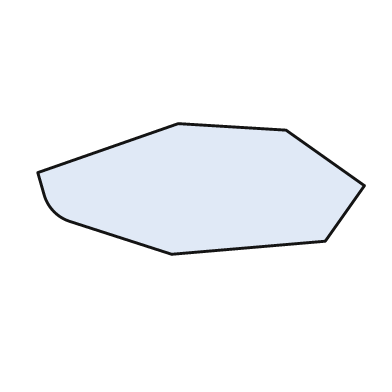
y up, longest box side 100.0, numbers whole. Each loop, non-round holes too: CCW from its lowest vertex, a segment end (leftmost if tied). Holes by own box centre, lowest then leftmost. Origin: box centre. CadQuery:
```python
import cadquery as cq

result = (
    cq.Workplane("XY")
    .moveTo(-9.0, -20.0)
    .lineTo(38.0, -16.0)
    .lineTo(50.0, 1.0)
    .lineTo(26.0, 18.0)
    .lineTo(-7.0, 20.0)
    .lineTo(-50.0, 5.0)
    .lineTo(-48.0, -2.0)
    .threePointArc((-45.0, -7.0), (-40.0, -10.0))
    .close()
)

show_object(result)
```